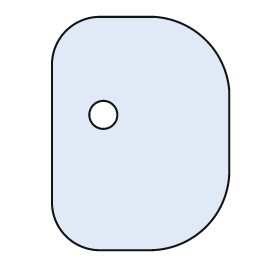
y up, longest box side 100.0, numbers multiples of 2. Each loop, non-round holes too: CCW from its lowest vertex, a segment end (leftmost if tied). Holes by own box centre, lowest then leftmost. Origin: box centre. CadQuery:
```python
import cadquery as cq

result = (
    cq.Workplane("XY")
    .moveTo(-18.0, -50.0)
    .lineTo(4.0, -50.0)
    .threePointArc((28.0, -40.0), (38.0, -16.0))
    .lineTo(38.0, 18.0)
    .threePointArc((28.0, 40.0), (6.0, 50.0))
    .lineTo(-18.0, 50.0)
    .threePointArc((-32.0, 44.0), (-38.0, 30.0))
    .lineTo(-38.0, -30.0)
    .threePointArc((-32.0, -44.0), (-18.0, -50.0))
    .close()
    .moveTo(-16.0, 8.0)
    .circle(6.0)
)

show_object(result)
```